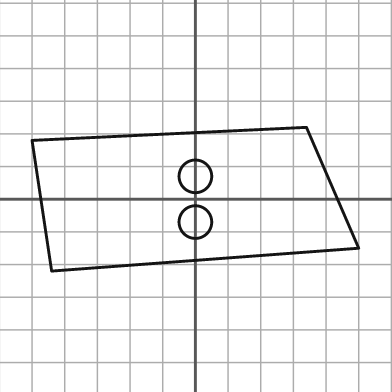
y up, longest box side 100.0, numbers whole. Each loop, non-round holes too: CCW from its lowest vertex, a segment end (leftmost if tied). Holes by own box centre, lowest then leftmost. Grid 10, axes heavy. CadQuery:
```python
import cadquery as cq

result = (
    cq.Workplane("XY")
    .moveTo(-44.0, -22.0)
    .lineTo(50.0, -15.0)
    .lineTo(34.0, 22.0)
    .lineTo(-50.0, 18.0)
    .close()
    .moveTo(0.0, -7.0)
    .circle(5.0)
    .moveTo(0.0, 7.0)
    .circle(5.0)
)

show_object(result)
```